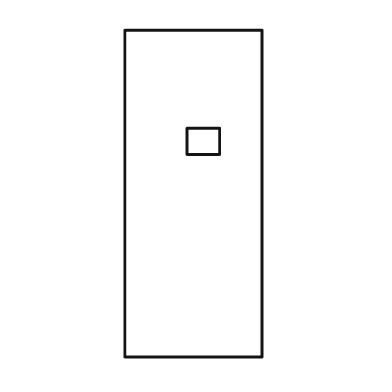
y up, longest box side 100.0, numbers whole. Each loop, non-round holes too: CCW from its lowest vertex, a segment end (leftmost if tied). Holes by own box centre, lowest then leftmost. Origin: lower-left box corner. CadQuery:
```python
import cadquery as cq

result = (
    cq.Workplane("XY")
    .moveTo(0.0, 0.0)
    .lineTo(42.0, 0.0)
    .lineTo(42.0, 100.0)
    .lineTo(0.0, 100.0)
    .close()
    .moveTo(19.0, 62.0)
    .lineTo(29.0, 62.0)
    .lineTo(29.0, 70.0)
    .lineTo(19.0, 70.0)
    .close()
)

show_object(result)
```